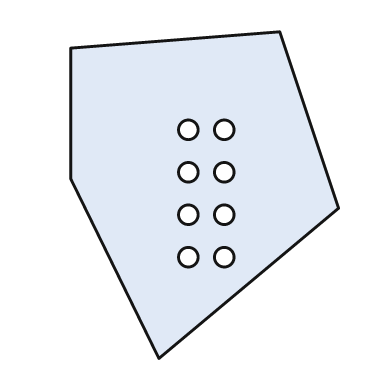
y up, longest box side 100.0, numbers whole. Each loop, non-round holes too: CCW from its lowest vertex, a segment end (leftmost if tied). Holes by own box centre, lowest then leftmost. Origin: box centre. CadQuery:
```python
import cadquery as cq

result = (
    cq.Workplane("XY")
    .moveTo(-14.0, -50.0)
    .lineTo(41.0, -4.0)
    .lineTo(23.0, 50.0)
    .lineTo(-41.0, 45.0)
    .lineTo(-41.0, 5.0)
    .close()
    .moveTo(-5.0, -19.0)
    .circle(3.0)
    .moveTo(6.0, -19.0)
    .circle(3.0)
    .moveTo(-5.0, -6.0)
    .circle(3.0)
    .moveTo(6.0, -6.0)
    .circle(3.0)
    .moveTo(-5.0, 7.0)
    .circle(3.0)
    .moveTo(6.0, 7.0)
    .circle(3.0)
    .moveTo(-5.0, 20.0)
    .circle(3.0)
    .moveTo(6.0, 20.0)
    .circle(3.0)
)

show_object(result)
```